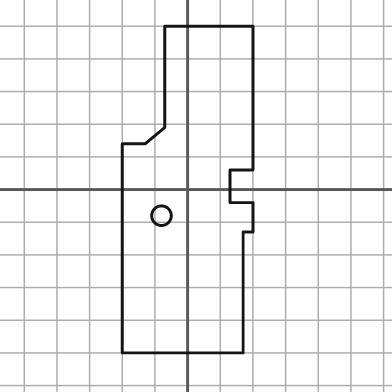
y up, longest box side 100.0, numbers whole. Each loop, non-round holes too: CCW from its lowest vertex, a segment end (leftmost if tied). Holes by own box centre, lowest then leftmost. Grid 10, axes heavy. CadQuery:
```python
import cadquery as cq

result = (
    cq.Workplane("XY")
    .moveTo(-20.0, -50.0)
    .lineTo(17.0, -50.0)
    .lineTo(17.0, -13.0)
    .lineTo(20.0, -13.0)
    .lineTo(20.0, -4.0)
    .lineTo(13.0, -4.0)
    .lineTo(13.0, 6.0)
    .lineTo(20.0, 6.0)
    .lineTo(20.0, 50.0)
    .lineTo(-7.0, 50.0)
    .lineTo(-7.0, 19.0)
    .lineTo(-13.0, 14.0)
    .lineTo(-20.0, 14.0)
    .close()
    .moveTo(-8.0, -8.0)
    .circle(3.0)
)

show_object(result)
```